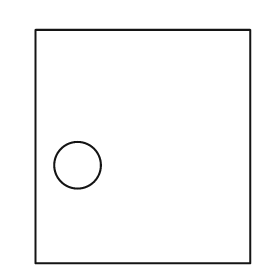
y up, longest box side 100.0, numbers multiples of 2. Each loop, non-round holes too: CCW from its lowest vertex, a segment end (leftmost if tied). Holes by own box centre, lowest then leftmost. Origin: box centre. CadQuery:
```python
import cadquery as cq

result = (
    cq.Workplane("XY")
    .moveTo(-46.0, -50.0)
    .lineTo(46.0, -50.0)
    .lineTo(46.0, 50.0)
    .lineTo(-46.0, 50.0)
    .close()
    .moveTo(-28.0, -8.0)
    .circle(10.0)
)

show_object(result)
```